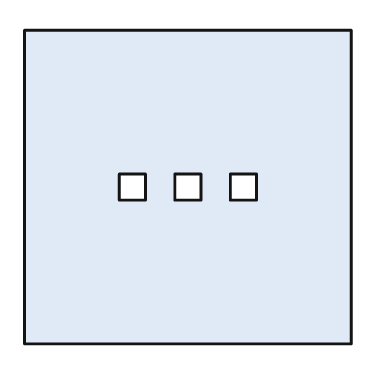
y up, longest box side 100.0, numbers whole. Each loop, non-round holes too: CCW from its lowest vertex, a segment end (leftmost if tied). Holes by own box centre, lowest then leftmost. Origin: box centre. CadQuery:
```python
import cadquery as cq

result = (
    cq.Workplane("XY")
    .moveTo(-50.0, -48.0)
    .lineTo(50.0, -48.0)
    .lineTo(50.0, 48.0)
    .lineTo(-50.0, 48.0)
    .close()
    .moveTo(-21.0, -4.0)
    .lineTo(-13.0, -4.0)
    .lineTo(-13.0, 4.0)
    .lineTo(-21.0, 4.0)
    .close()
    .moveTo(-4.0, -4.0)
    .lineTo(4.0, -4.0)
    .lineTo(4.0, 4.0)
    .lineTo(-4.0, 4.0)
    .close()
    .moveTo(13.0, -4.0)
    .lineTo(21.0, -4.0)
    .lineTo(21.0, 4.0)
    .lineTo(13.0, 4.0)
    .close()
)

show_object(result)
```